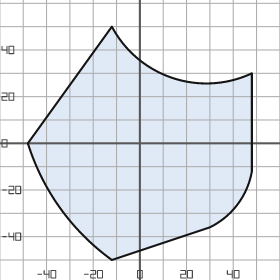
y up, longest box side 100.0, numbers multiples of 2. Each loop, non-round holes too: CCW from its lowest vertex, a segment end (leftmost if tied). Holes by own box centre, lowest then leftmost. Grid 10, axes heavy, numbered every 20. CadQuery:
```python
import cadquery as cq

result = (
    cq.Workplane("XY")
    .moveTo(-12.0, -50.0)
    .lineTo(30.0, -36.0)
    .threePointArc((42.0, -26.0), (48.0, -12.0))
    .lineTo(48.0, 30.0)
    .threePointArc((14.0, 28.0), (-12.0, 50.0))
    .lineTo(-48.0, 0.0)
    .threePointArc((-34.0, -28.0), (-12.0, -50.0))
    .close()
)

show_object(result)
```